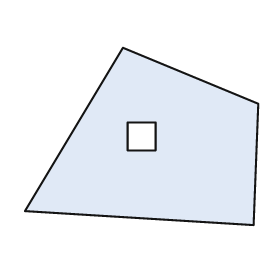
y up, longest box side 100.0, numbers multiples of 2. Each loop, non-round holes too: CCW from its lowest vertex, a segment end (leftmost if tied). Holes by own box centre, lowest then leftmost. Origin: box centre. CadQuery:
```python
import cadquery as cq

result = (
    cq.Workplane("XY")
    .moveTo(48.0, -38.0)
    .lineTo(50.0, 14.0)
    .lineTo(-8.0, 38.0)
    .lineTo(-50.0, -32.0)
    .close()
    .moveTo(-6.0, -6.0)
    .lineTo(6.0, -6.0)
    .lineTo(6.0, 6.0)
    .lineTo(-6.0, 6.0)
    .close()
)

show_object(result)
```